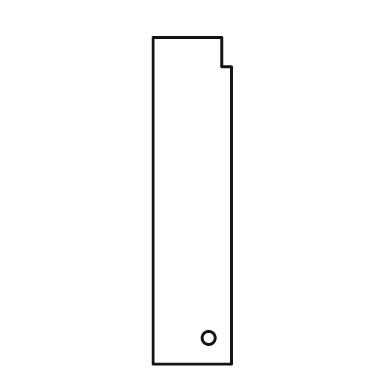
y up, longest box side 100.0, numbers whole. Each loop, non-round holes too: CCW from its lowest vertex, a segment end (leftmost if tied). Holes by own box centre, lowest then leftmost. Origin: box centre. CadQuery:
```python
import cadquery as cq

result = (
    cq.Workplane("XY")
    .moveTo(-12.0, -50.0)
    .lineTo(12.0, -50.0)
    .lineTo(12.0, 41.0)
    .lineTo(9.0, 41.0)
    .lineTo(9.0, 50.0)
    .lineTo(-12.0, 50.0)
    .close()
    .moveTo(5.0, -42.0)
    .circle(2.0)
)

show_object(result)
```